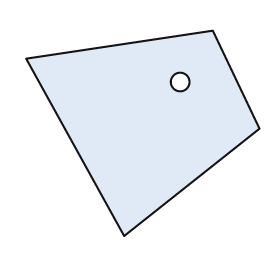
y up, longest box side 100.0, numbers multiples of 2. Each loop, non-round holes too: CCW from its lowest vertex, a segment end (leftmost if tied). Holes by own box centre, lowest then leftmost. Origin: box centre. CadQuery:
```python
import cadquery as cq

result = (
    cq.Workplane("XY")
    .moveTo(-8.0, -44.0)
    .lineTo(50.0, 2.0)
    .lineTo(30.0, 44.0)
    .lineTo(-50.0, 32.0)
    .close()
    .moveTo(16.0, 22.0)
    .circle(4.0)
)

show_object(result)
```